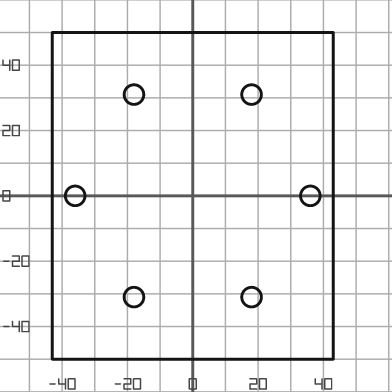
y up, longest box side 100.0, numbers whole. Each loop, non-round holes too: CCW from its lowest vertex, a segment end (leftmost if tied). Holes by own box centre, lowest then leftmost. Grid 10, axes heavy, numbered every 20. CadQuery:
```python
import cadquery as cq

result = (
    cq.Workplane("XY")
    .moveTo(-43.0, -50.0)
    .lineTo(43.0, -50.0)
    .lineTo(43.0, 50.0)
    .lineTo(-43.0, 50.0)
    .close()
    .moveTo(-18.0, -31.0)
    .circle(3.0)
    .moveTo(18.0, -31.0)
    .circle(3.0)
    .moveTo(-36.0, 0.0)
    .circle(3.0)
    .moveTo(36.0, 0.0)
    .circle(3.0)
    .moveTo(-18.0, 31.0)
    .circle(3.0)
    .moveTo(18.0, 31.0)
    .circle(3.0)
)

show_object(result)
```